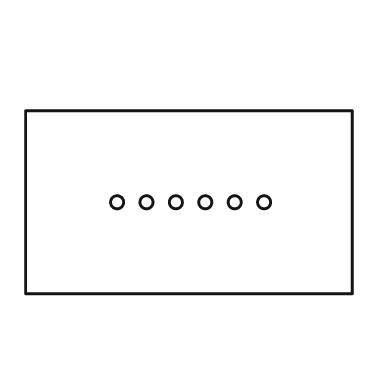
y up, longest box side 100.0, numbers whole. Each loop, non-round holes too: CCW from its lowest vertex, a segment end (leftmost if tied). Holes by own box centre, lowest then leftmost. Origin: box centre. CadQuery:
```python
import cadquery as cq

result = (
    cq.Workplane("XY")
    .moveTo(-50.0, -28.0)
    .lineTo(50.0, -28.0)
    .lineTo(50.0, 28.0)
    .lineTo(-50.0, 28.0)
    .close()
    .moveTo(-22.0, 0.0)
    .circle(2.0)
    .moveTo(-13.0, 0.0)
    .circle(2.0)
    .moveTo(-4.0, 0.0)
    .circle(2.0)
    .moveTo(5.0, 0.0)
    .circle(2.0)
    .moveTo(14.0, 0.0)
    .circle(2.0)
    .moveTo(23.0, 0.0)
    .circle(2.0)
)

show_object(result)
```